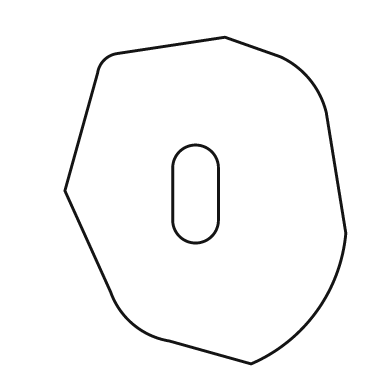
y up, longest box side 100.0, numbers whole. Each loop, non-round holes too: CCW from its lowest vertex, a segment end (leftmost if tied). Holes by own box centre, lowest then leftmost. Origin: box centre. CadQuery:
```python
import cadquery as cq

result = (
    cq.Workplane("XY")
    .moveTo(14.0, -50.0)
    .threePointArc((34.0, -34.0), (43.0, -10.0))
    .lineTo(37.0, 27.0)
    .threePointArc((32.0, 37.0), (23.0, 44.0))
    .lineTo(6.0, 50.0)
    .lineTo(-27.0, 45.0)
    .threePointArc((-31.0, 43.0), (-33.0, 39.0))
    .lineTo(-43.0, 3.0)
    .lineTo(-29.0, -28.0)
    .threePointArc((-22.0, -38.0), (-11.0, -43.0))
    .close()
    .moveTo(-10.0, -6.0)
    .threePointArc((-3.0, -13.0), (4.0, -6.0))
    .lineTo(4.0, 10.0)
    .threePointArc((-3.0, 17.0), (-10.0, 10.0))
    .close()
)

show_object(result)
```